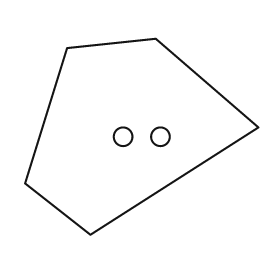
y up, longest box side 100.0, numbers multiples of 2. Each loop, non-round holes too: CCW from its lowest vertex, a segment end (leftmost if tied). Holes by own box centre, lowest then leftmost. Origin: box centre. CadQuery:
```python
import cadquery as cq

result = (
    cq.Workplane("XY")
    .moveTo(-22.0, -42.0)
    .lineTo(50.0, 4.0)
    .lineTo(6.0, 42.0)
    .lineTo(-32.0, 38.0)
    .lineTo(-50.0, -20.0)
    .close()
    .moveTo(-8.0, 0.0)
    .circle(4.0)
    .moveTo(8.0, 0.0)
    .circle(4.0)
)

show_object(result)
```